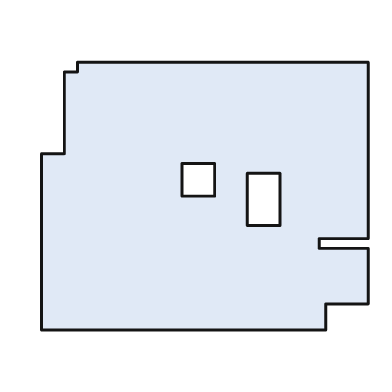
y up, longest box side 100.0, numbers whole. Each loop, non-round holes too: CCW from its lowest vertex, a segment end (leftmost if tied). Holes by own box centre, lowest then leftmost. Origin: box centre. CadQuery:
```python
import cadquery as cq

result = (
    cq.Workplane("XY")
    .moveTo(-50.0, -41.0)
    .lineTo(37.0, -41.0)
    .lineTo(37.0, -33.0)
    .lineTo(50.0, -33.0)
    .lineTo(50.0, -16.0)
    .lineTo(35.0, -16.0)
    .lineTo(35.0, -13.0)
    .lineTo(50.0, -13.0)
    .lineTo(50.0, 41.0)
    .lineTo(-39.0, 41.0)
    .lineTo(-39.0, 38.0)
    .lineTo(-43.0, 38.0)
    .lineTo(-43.0, 13.0)
    .lineTo(-50.0, 13.0)
    .close()
    .moveTo(13.0, -9.0)
    .lineTo(23.0, -9.0)
    .lineTo(23.0, 7.0)
    .lineTo(13.0, 7.0)
    .close()
    .moveTo(-7.0, 0.0)
    .lineTo(3.0, 0.0)
    .lineTo(3.0, 10.0)
    .lineTo(-7.0, 10.0)
    .close()
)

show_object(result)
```